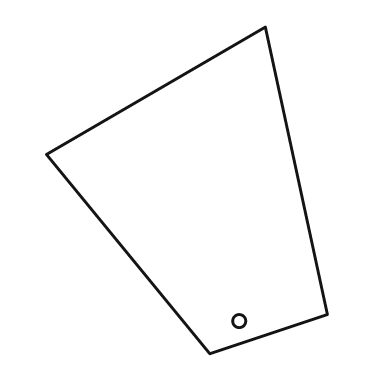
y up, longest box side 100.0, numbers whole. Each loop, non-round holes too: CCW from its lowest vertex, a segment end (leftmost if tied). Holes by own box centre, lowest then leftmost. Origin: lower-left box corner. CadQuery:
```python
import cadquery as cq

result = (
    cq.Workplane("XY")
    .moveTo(50.0, 0.0)
    .lineTo(86.0, 12.0)
    .lineTo(67.0, 100.0)
    .lineTo(0.0, 61.0)
    .close()
    .moveTo(59.0, 10.0)
    .circle(2.0)
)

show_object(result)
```